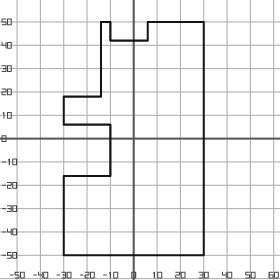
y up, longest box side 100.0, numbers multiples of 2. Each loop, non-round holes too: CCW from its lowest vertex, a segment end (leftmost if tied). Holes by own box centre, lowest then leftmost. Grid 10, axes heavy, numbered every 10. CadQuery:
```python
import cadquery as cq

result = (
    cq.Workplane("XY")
    .moveTo(-30.0, -50.0)
    .lineTo(30.0, -50.0)
    .lineTo(30.0, 50.0)
    .lineTo(6.0, 50.0)
    .lineTo(6.0, 42.0)
    .lineTo(-10.0, 42.0)
    .lineTo(-10.0, 50.0)
    .lineTo(-14.0, 50.0)
    .lineTo(-14.0, 18.0)
    .lineTo(-30.0, 18.0)
    .lineTo(-30.0, 6.0)
    .lineTo(-10.0, 6.0)
    .lineTo(-10.0, -16.0)
    .lineTo(-30.0, -16.0)
    .close()
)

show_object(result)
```